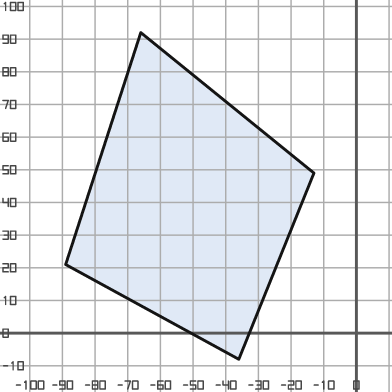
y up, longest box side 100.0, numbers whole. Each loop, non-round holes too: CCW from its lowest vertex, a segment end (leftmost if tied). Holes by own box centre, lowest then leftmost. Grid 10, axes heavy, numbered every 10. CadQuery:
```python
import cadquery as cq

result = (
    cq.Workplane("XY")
    .moveTo(-36.0, -8.0)
    .lineTo(-13.0, 49.0)
    .lineTo(-66.0, 92.0)
    .lineTo(-89.0, 21.0)
    .close()
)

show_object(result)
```